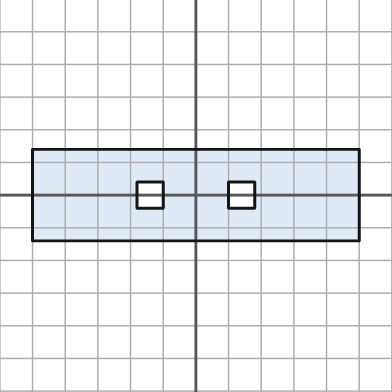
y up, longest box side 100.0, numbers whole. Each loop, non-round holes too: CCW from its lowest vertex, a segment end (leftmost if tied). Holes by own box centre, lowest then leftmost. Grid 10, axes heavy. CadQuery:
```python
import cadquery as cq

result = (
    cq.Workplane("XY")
    .moveTo(-50.0, -14.0)
    .lineTo(50.0, -14.0)
    .lineTo(50.0, 14.0)
    .lineTo(-50.0, 14.0)
    .close()
    .moveTo(-18.0, -4.0)
    .lineTo(-10.0, -4.0)
    .lineTo(-10.0, 4.0)
    .lineTo(-18.0, 4.0)
    .close()
    .moveTo(10.0, -4.0)
    .lineTo(18.0, -4.0)
    .lineTo(18.0, 4.0)
    .lineTo(10.0, 4.0)
    .close()
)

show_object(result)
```